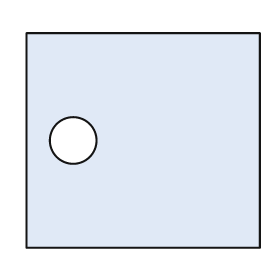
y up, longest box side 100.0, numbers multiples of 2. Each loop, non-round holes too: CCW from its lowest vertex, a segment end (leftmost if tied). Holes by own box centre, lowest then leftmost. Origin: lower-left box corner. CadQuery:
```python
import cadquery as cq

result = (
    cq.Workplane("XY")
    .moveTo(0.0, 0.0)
    .lineTo(100.0, 0.0)
    .lineTo(100.0, 92.0)
    .lineTo(0.0, 92.0)
    .close()
    .moveTo(20.0, 46.0)
    .circle(10.0)
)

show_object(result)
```